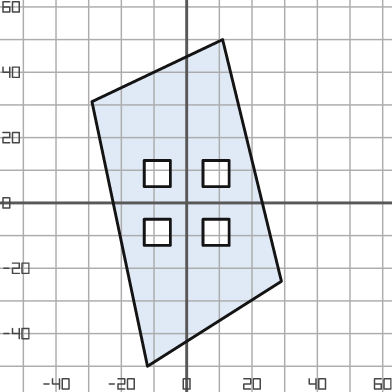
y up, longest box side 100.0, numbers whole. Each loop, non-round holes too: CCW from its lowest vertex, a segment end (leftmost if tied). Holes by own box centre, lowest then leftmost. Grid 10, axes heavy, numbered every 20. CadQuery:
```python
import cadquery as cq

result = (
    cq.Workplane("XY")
    .moveTo(-12.0, -50.0)
    .lineTo(29.0, -24.0)
    .lineTo(11.0, 50.0)
    .lineTo(-29.0, 31.0)
    .close()
    .moveTo(-13.0, -13.0)
    .lineTo(-5.0, -13.0)
    .lineTo(-5.0, -5.0)
    .lineTo(-13.0, -5.0)
    .close()
    .moveTo(5.0, -13.0)
    .lineTo(13.0, -13.0)
    .lineTo(13.0, -5.0)
    .lineTo(5.0, -5.0)
    .close()
    .moveTo(-13.0, 5.0)
    .lineTo(-5.0, 5.0)
    .lineTo(-5.0, 13.0)
    .lineTo(-13.0, 13.0)
    .close()
    .moveTo(5.0, 5.0)
    .lineTo(13.0, 5.0)
    .lineTo(13.0, 13.0)
    .lineTo(5.0, 13.0)
    .close()
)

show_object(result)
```